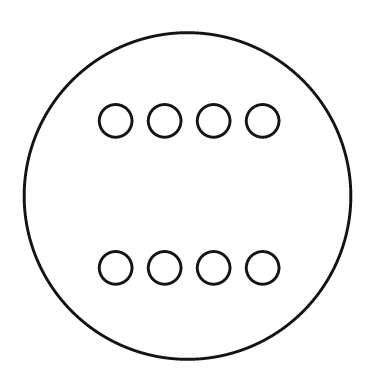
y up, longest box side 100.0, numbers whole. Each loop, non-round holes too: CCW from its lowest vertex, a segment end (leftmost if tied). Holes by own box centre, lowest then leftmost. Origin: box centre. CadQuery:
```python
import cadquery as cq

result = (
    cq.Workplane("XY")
    .moveTo(0.0, 0.0)
    .circle(50.0)
    .moveTo(-22.0, -22.0)
    .circle(5.0)
    .moveTo(-7.0, -22.0)
    .circle(5.0)
    .moveTo(8.0, -22.0)
    .circle(5.0)
    .moveTo(23.0, -22.0)
    .circle(5.0)
    .moveTo(-22.0, 23.0)
    .circle(5.0)
    .moveTo(-7.0, 23.0)
    .circle(5.0)
    .moveTo(8.0, 23.0)
    .circle(5.0)
    .moveTo(23.0, 23.0)
    .circle(5.0)
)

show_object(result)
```